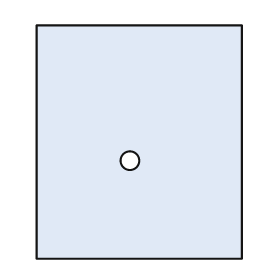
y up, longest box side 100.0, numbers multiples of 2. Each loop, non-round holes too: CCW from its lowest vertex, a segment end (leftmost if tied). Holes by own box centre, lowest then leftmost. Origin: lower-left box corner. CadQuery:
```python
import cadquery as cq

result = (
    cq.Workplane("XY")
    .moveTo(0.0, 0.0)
    .lineTo(88.0, 0.0)
    .lineTo(88.0, 100.0)
    .lineTo(0.0, 100.0)
    .close()
    .moveTo(40.0, 42.0)
    .circle(4.0)
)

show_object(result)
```